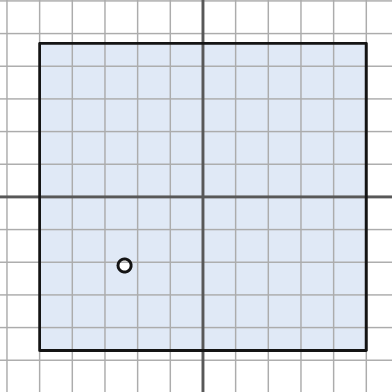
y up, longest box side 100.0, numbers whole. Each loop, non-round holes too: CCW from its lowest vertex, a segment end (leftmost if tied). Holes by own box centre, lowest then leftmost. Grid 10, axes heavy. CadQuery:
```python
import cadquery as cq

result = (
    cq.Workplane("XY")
    .moveTo(-50.0, -47.0)
    .lineTo(50.0, -47.0)
    .lineTo(50.0, 47.0)
    .lineTo(-50.0, 47.0)
    .close()
    .moveTo(-24.0, -21.0)
    .circle(2.0)
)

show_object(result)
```